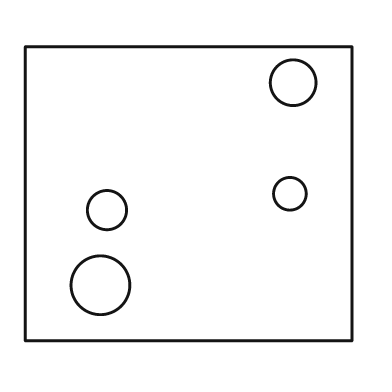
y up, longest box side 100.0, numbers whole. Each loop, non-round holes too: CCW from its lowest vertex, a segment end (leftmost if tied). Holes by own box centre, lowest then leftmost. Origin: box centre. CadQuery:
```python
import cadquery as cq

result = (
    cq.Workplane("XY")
    .moveTo(-50.0, -45.0)
    .lineTo(50.0, -45.0)
    .lineTo(50.0, 45.0)
    .lineTo(-50.0, 45.0)
    .close()
    .moveTo(-27.0, -28.0)
    .circle(9.0)
    .moveTo(-25.0, -5.0)
    .circle(6.0)
    .moveTo(31.0, 0.0)
    .circle(5.0)
    .moveTo(32.0, 34.0)
    .circle(7.0)
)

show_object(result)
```